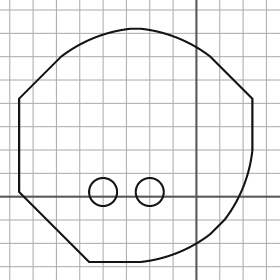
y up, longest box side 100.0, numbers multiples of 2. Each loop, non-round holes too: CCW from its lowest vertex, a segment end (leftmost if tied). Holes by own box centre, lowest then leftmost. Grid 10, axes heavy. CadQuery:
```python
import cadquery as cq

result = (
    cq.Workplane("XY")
    .moveTo(-46.0, -28.0)
    .lineTo(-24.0, -28.0)
    .threePointArc((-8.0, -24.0), (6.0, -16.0))
    .lineTo(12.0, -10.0)
    .threePointArc((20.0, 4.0), (24.0, 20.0))
    .lineTo(24.0, 42.0)
    .lineTo(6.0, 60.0)
    .threePointArc((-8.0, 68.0), (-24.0, 72.0))
    .lineTo(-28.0, 72.0)
    .threePointArc((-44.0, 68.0), (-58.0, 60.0))
    .lineTo(-76.0, 42.0)
    .lineTo(-76.0, 2.0)
    .close()
    .moveTo(-40.0, 2.0)
    .circle(6.0)
    .moveTo(-20.0, 2.0)
    .circle(6.0)
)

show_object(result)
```